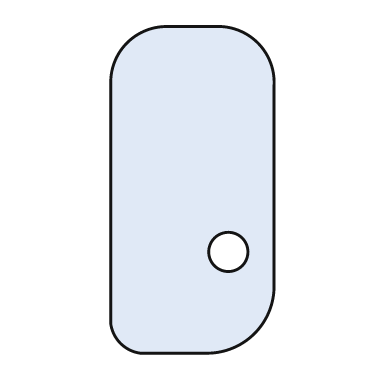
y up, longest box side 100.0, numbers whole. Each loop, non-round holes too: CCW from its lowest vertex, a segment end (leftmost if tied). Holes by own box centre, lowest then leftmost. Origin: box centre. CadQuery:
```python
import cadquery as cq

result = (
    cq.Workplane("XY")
    .moveTo(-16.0, -50.0)
    .lineTo(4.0, -50.0)
    .threePointArc((19.0, -44.0), (25.0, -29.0))
    .lineTo(25.0, 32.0)
    .threePointArc((20.0, 45.0), (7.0, 50.0))
    .lineTo(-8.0, 50.0)
    .threePointArc((-20.0, 45.0), (-25.0, 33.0))
    .lineTo(-25.0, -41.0)
    .threePointArc((-22.0, -47.0), (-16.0, -50.0))
    .close()
    .moveTo(11.0, -19.0)
    .circle(6.0)
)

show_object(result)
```